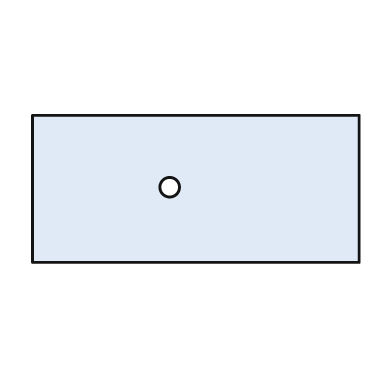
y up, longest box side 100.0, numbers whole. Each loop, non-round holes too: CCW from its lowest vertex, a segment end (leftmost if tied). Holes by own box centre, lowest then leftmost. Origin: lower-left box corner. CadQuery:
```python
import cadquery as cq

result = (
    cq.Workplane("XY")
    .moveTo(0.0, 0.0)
    .lineTo(100.0, 0.0)
    .lineTo(100.0, 45.0)
    .lineTo(0.0, 45.0)
    .close()
    .moveTo(42.0, 23.0)
    .circle(3.0)
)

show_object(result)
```